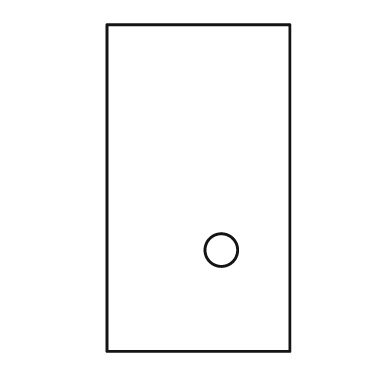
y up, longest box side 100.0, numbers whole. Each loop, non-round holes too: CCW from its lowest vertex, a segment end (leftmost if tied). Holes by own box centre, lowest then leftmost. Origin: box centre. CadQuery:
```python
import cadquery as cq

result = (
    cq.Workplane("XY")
    .moveTo(-28.0, -50.0)
    .lineTo(28.0, -50.0)
    .lineTo(28.0, 50.0)
    .lineTo(-28.0, 50.0)
    .close()
    .moveTo(7.0, -19.0)
    .circle(5.0)
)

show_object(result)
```